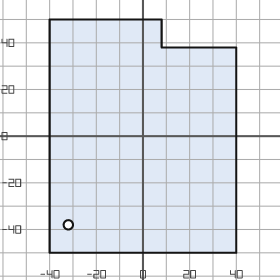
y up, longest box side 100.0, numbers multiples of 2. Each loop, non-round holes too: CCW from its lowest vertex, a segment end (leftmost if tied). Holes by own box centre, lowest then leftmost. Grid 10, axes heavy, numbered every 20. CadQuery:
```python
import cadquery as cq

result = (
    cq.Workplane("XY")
    .moveTo(-40.0, -50.0)
    .lineTo(40.0, -50.0)
    .lineTo(40.0, 38.0)
    .lineTo(8.0, 38.0)
    .lineTo(8.0, 50.0)
    .lineTo(-40.0, 50.0)
    .close()
    .moveTo(-32.0, -38.0)
    .circle(2.0)
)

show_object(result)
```